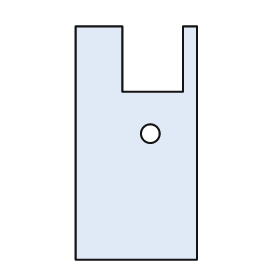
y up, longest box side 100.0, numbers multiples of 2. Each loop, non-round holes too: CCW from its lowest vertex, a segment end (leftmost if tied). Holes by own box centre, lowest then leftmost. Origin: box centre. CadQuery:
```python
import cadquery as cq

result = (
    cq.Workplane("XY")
    .moveTo(-26.0, -50.0)
    .lineTo(26.0, -50.0)
    .lineTo(26.0, 50.0)
    .lineTo(20.0, 50.0)
    .lineTo(20.0, 22.0)
    .lineTo(-6.0, 22.0)
    .lineTo(-6.0, 50.0)
    .lineTo(-26.0, 50.0)
    .close()
    .moveTo(6.0, 4.0)
    .circle(4.0)
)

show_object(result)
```